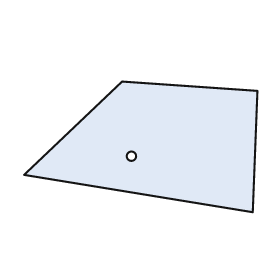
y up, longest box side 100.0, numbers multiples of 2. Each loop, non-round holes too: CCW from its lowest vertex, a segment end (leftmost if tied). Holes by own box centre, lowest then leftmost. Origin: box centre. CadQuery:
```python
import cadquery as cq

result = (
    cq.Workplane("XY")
    .moveTo(48.0, -28.0)
    .lineTo(50.0, 24.0)
    .lineTo(-8.0, 28.0)
    .lineTo(-50.0, -12.0)
    .close()
    .moveTo(-4.0, -4.0)
    .circle(2.0)
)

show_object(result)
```